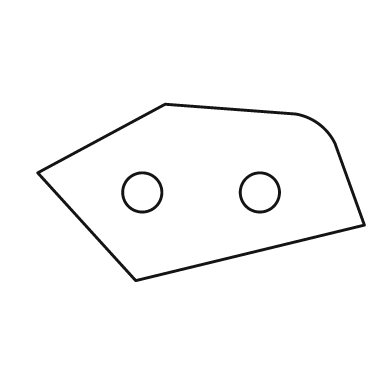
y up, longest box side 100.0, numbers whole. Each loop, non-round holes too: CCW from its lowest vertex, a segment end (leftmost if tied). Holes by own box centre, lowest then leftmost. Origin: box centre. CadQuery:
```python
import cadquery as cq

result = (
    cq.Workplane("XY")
    .moveTo(-20.0, -27.0)
    .lineTo(50.0, -10.0)
    .lineTo(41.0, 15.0)
    .threePointArc((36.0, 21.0), (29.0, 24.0))
    .lineTo(-11.0, 27.0)
    .lineTo(-50.0, 6.0)
    .close()
    .moveTo(-18.0, 0.0)
    .circle(6.0)
    .moveTo(18.0, 0.0)
    .circle(6.0)
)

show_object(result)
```